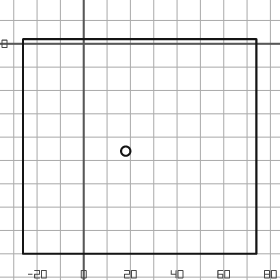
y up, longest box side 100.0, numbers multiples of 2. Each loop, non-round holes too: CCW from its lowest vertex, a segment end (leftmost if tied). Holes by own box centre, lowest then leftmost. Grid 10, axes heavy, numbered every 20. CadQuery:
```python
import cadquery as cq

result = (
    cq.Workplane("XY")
    .moveTo(-26.0, -90.0)
    .lineTo(74.0, -90.0)
    .lineTo(74.0, 2.0)
    .lineTo(-26.0, 2.0)
    .close()
    .moveTo(18.0, -46.0)
    .circle(2.0)
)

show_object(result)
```